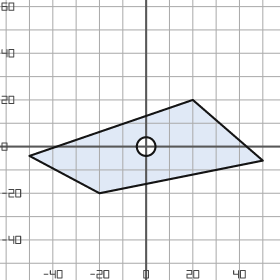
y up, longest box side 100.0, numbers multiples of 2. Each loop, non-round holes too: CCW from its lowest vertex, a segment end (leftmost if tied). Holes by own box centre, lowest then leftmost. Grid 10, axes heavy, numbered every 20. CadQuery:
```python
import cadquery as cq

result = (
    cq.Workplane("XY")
    .moveTo(-20.0, -20.0)
    .lineTo(50.0, -6.0)
    .lineTo(20.0, 20.0)
    .lineTo(-50.0, -4.0)
    .close()
    .moveTo(0.0, 0.0)
    .circle(4.0)
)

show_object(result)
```